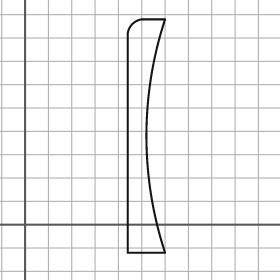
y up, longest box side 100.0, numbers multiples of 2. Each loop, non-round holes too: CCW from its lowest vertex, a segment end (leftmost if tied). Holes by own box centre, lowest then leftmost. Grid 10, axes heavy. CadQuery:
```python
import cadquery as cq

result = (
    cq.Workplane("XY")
    .moveTo(44.0, -12.0)
    .lineTo(60.0, -12.0)
    .threePointArc((52.0, 38.0), (60.0, 88.0))
    .lineTo(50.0, 88.0)
    .threePointArc((46.0, 86.0), (44.0, 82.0))
    .close()
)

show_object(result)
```